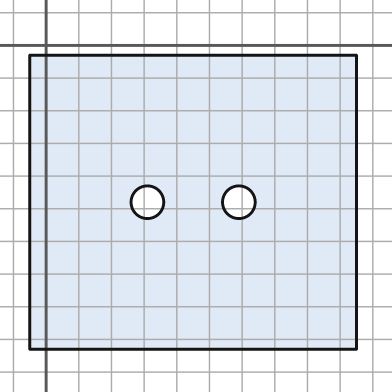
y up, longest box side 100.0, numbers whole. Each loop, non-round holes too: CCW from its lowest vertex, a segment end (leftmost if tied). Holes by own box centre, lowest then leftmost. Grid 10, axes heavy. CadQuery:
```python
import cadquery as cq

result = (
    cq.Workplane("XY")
    .moveTo(-5.0, -93.0)
    .lineTo(95.0, -93.0)
    .lineTo(95.0, -3.0)
    .lineTo(-5.0, -3.0)
    .close()
    .moveTo(31.0, -48.0)
    .circle(5.0)
    .moveTo(59.0, -48.0)
    .circle(5.0)
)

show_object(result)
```